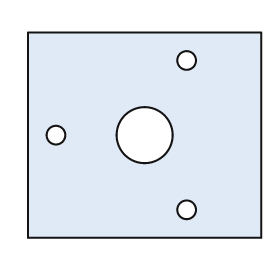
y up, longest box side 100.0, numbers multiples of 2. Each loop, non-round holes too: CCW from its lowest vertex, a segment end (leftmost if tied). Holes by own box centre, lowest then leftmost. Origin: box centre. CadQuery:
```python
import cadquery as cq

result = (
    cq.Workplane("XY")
    .moveTo(-50.0, -44.0)
    .lineTo(50.0, -44.0)
    .lineTo(50.0, 44.0)
    .lineTo(-50.0, 44.0)
    .close()
    .moveTo(18.0, -32.0)
    .circle(4.0)
    .moveTo(-38.0, 0.0)
    .circle(4.0)
    .moveTo(0.0, 0.0)
    .circle(12.0)
    .moveTo(18.0, 32.0)
    .circle(4.0)
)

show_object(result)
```